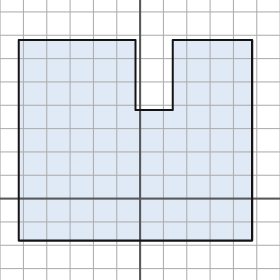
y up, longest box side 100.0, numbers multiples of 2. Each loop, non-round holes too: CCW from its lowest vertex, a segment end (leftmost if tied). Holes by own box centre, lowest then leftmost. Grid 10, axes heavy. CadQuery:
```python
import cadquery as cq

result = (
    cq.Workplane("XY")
    .moveTo(-52.0, -18.0)
    .lineTo(48.0, -18.0)
    .lineTo(48.0, 68.0)
    .lineTo(14.0, 68.0)
    .lineTo(14.0, 38.0)
    .lineTo(-2.0, 38.0)
    .lineTo(-2.0, 68.0)
    .lineTo(-52.0, 68.0)
    .close()
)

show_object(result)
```